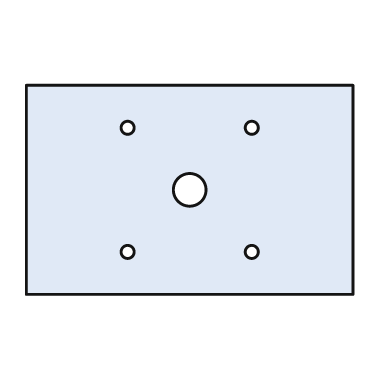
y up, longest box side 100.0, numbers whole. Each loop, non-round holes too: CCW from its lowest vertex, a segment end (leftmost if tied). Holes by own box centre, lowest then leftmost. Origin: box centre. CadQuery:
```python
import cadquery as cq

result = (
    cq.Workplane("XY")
    .moveTo(-50.0, -32.0)
    .lineTo(50.0, -32.0)
    .lineTo(50.0, 32.0)
    .lineTo(-50.0, 32.0)
    .close()
    .moveTo(-19.0, -19.0)
    .circle(2.0)
    .moveTo(19.0, -19.0)
    .circle(2.0)
    .moveTo(0.0, 0.0)
    .circle(5.0)
    .moveTo(-19.0, 19.0)
    .circle(2.0)
    .moveTo(19.0, 19.0)
    .circle(2.0)
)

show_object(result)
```